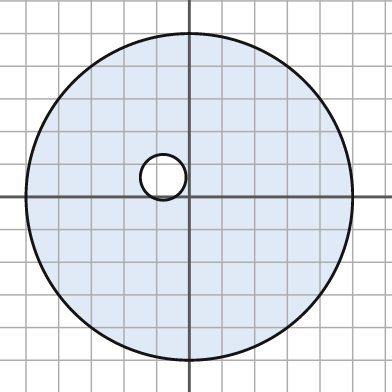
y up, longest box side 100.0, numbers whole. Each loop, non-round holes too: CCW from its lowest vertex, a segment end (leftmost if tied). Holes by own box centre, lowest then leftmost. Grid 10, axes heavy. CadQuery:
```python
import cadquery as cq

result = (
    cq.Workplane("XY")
    .moveTo(0.0, 0.0)
    .circle(50.0)
    .moveTo(-8.0, 6.0)
    .circle(7.0)
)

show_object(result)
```